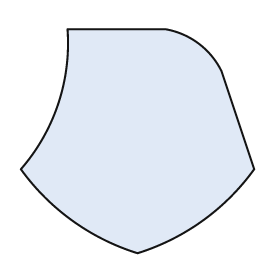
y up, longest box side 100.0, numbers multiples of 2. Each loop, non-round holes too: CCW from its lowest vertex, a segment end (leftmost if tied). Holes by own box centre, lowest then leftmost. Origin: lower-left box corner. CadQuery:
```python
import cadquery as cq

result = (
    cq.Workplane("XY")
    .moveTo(50.0, 0.0)
    .threePointArc((78.0, 14.0), (100.0, 36.0))
    .lineTo(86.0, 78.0)
    .threePointArc((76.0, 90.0), (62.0, 96.0))
    .lineTo(20.0, 96.0)
    .threePointArc((16.0, 64.0), (0.0, 36.0))
    .threePointArc((22.0, 14.0), (50.0, 0.0))
    .close()
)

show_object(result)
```